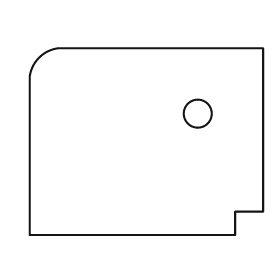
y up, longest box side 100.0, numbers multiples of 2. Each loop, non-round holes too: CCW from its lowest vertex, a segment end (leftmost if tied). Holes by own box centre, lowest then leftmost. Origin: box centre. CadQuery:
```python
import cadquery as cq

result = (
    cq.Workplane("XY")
    .moveTo(-50.0, -40.0)
    .lineTo(38.0, -40.0)
    .lineTo(38.0, -30.0)
    .lineTo(50.0, -30.0)
    .lineTo(50.0, 40.0)
    .lineTo(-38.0, 40.0)
    .threePointArc((-46.0, 36.0), (-50.0, 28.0))
    .close()
    .moveTo(22.0, 12.0)
    .circle(6.0)
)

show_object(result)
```